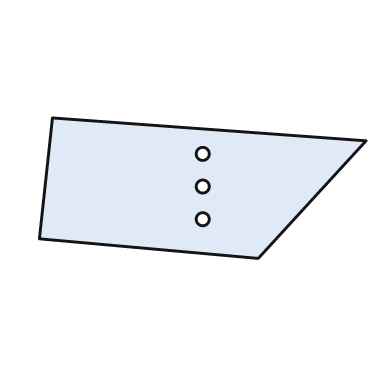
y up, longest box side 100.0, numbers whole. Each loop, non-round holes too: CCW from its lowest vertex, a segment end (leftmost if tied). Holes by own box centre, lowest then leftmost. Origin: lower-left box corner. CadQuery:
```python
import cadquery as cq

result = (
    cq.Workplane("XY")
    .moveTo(67.0, 0.0)
    .lineTo(100.0, 36.0)
    .lineTo(4.0, 43.0)
    .lineTo(0.0, 6.0)
    .close()
    .moveTo(50.0, 12.0)
    .circle(2.0)
    .moveTo(50.0, 22.0)
    .circle(2.0)
    .moveTo(50.0, 32.0)
    .circle(2.0)
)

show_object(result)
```